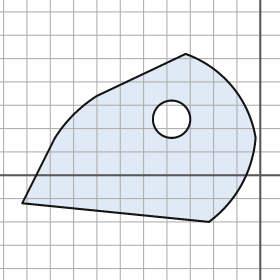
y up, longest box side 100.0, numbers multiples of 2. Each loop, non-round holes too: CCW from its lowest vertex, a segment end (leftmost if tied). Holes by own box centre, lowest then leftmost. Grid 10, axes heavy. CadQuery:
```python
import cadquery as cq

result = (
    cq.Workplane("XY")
    .moveTo(-22.0, -20.0)
    .threePointArc((-8.0, -4.0), (-2.0, 16.0))
    .threePointArc((-12.0, 38.0), (-32.0, 52.0))
    .lineTo(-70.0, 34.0)
    .threePointArc((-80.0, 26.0), (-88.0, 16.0))
    .lineTo(-102.0, -12.0)
    .close()
    .moveTo(-38.0, 24.0)
    .circle(8.0)
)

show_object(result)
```